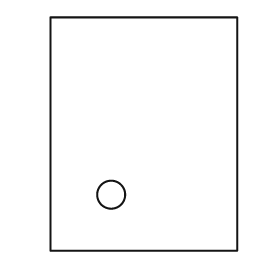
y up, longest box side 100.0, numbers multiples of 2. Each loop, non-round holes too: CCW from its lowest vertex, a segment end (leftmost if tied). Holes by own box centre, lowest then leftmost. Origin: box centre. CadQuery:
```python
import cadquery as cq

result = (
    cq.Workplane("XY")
    .moveTo(-40.0, -50.0)
    .lineTo(40.0, -50.0)
    .lineTo(40.0, 50.0)
    .lineTo(-40.0, 50.0)
    .close()
    .moveTo(-14.0, -26.0)
    .circle(6.0)
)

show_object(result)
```